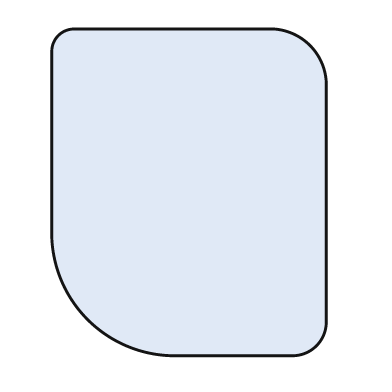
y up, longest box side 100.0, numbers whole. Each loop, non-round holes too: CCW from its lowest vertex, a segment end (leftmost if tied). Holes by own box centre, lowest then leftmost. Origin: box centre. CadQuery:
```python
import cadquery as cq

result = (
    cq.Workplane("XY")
    .moveTo(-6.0, -50.0)
    .lineTo(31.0, -50.0)
    .threePointArc((39.0, -47.0), (42.0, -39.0))
    .lineTo(42.0, 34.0)
    .threePointArc((37.0, 45.0), (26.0, 50.0))
    .lineTo(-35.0, 50.0)
    .threePointArc((-40.0, 48.0), (-42.0, 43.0))
    .lineTo(-42.0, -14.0)
    .threePointArc((-31.0, -39.0), (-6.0, -50.0))
    .close()
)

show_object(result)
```